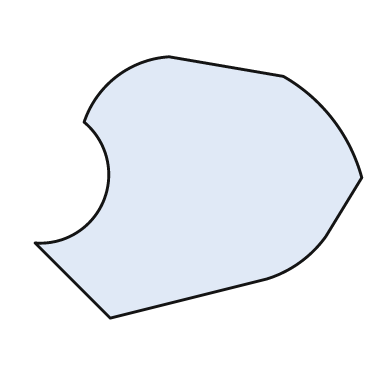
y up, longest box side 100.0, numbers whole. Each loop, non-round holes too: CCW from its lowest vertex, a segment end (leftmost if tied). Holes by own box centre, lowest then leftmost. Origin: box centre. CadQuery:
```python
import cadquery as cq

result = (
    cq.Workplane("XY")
    .moveTo(-27.0, -40.0)
    .lineTo(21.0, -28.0)
    .threePointArc((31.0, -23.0), (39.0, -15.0))
    .lineTo(50.0, 3.0)
    .threePointArc((41.0, 21.0), (26.0, 34.0))
    .lineTo(-9.0, 40.0)
    .threePointArc((-25.0, 34.0), (-35.0, 20.0))
    .threePointArc((-29.0, -4.0), (-50.0, -17.0))
    .close()
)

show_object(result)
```